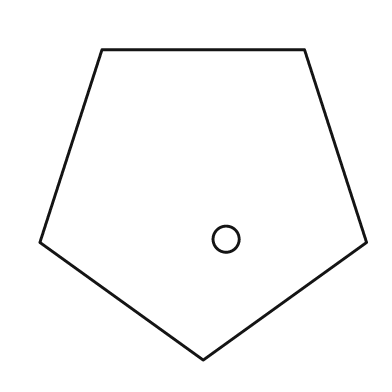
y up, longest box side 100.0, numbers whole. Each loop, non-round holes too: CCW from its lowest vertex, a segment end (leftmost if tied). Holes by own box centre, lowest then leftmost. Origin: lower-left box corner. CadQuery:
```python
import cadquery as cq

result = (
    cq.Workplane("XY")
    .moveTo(50.0, 0.0)
    .lineTo(100.0, 36.0)
    .lineTo(81.0, 95.0)
    .lineTo(19.0, 95.0)
    .lineTo(0.0, 36.0)
    .close()
    .moveTo(57.0, 37.0)
    .circle(4.0)
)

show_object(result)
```